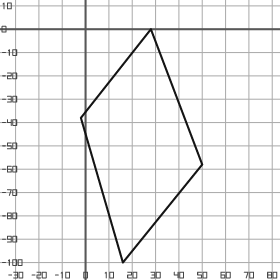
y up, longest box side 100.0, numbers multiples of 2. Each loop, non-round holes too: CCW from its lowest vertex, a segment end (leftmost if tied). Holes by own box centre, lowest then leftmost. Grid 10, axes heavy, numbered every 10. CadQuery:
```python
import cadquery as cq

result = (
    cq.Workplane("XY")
    .moveTo(16.0, -100.0)
    .lineTo(50.0, -58.0)
    .lineTo(28.0, 0.0)
    .lineTo(-2.0, -38.0)
    .close()
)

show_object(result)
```